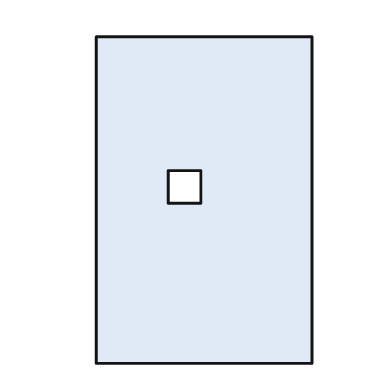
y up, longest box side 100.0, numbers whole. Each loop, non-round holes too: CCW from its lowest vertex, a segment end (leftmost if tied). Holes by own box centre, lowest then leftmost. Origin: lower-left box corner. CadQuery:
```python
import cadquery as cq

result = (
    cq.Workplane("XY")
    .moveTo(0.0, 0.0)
    .lineTo(66.0, 0.0)
    .lineTo(66.0, 100.0)
    .lineTo(0.0, 100.0)
    .close()
    .moveTo(22.0, 49.0)
    .lineTo(32.0, 49.0)
    .lineTo(32.0, 59.0)
    .lineTo(22.0, 59.0)
    .close()
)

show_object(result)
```